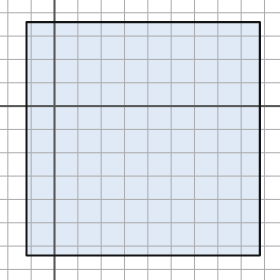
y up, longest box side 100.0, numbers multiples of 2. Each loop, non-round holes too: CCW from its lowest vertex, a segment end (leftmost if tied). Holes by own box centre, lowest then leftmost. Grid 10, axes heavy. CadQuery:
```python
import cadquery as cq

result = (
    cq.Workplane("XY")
    .moveTo(-12.0, -64.0)
    .lineTo(88.0, -64.0)
    .lineTo(88.0, 36.0)
    .lineTo(-12.0, 36.0)
    .close()
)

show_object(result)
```